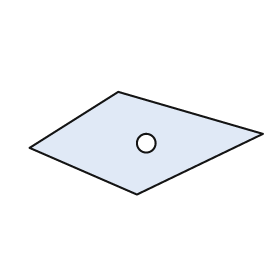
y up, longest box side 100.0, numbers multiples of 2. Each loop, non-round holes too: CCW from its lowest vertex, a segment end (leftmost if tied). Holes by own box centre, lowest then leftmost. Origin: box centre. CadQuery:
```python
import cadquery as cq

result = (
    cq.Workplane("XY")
    .moveTo(-4.0, -22.0)
    .lineTo(50.0, 4.0)
    .lineTo(-12.0, 22.0)
    .lineTo(-50.0, -2.0)
    .close()
    .moveTo(0.0, 0.0)
    .circle(4.0)
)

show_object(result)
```